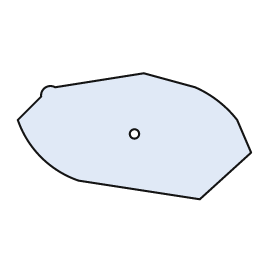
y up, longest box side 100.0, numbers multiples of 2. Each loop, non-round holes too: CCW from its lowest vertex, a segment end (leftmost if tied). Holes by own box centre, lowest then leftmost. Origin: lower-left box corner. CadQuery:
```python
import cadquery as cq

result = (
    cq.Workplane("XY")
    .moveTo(78.0, 0.0)
    .lineTo(100.0, 20.0)
    .lineTo(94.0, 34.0)
    .threePointArc((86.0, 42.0), (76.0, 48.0))
    .lineTo(54.0, 54.0)
    .lineTo(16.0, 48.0)
    .threePointArc((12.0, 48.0), (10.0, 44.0))
    .lineTo(0.0, 34.0)
    .threePointArc((10.0, 18.0), (26.0, 8.0))
    .close()
    .moveTo(50.0, 28.0)
    .circle(2.0)
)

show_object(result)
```